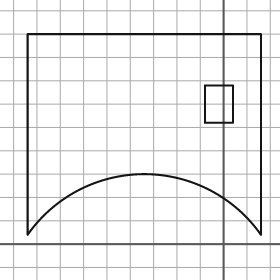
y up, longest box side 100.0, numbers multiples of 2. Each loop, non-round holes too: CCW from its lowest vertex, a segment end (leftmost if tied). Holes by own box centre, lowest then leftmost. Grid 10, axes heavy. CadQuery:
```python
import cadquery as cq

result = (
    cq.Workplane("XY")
    .moveTo(-84.0, 4.0)
    .threePointArc((-34.0, 30.0), (16.0, 4.0))
    .lineTo(16.0, 90.0)
    .lineTo(-84.0, 90.0)
    .close()
    .moveTo(-8.0, 52.0)
    .lineTo(4.0, 52.0)
    .lineTo(4.0, 68.0)
    .lineTo(-8.0, 68.0)
    .close()
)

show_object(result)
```